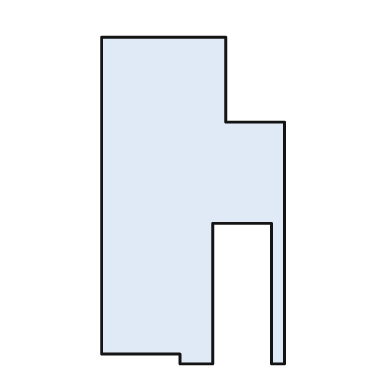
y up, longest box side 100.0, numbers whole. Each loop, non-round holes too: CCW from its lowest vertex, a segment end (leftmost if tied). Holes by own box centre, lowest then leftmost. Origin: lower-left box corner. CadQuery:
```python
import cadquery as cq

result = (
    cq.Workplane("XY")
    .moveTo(24.0, 0.0)
    .lineTo(34.0, 0.0)
    .lineTo(34.0, 43.0)
    .lineTo(52.0, 43.0)
    .lineTo(52.0, 0.0)
    .lineTo(56.0, 0.0)
    .lineTo(56.0, 74.0)
    .lineTo(38.0, 74.0)
    .lineTo(38.0, 100.0)
    .lineTo(0.0, 100.0)
    .lineTo(0.0, 3.0)
    .lineTo(24.0, 3.0)
    .close()
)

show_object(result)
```